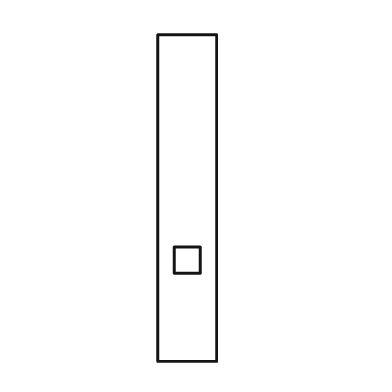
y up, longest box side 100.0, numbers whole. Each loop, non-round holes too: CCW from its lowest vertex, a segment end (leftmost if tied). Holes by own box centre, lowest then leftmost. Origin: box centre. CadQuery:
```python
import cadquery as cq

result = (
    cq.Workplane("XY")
    .moveTo(-9.0, -50.0)
    .lineTo(9.0, -50.0)
    .lineTo(9.0, 50.0)
    .lineTo(-9.0, 50.0)
    .close()
    .moveTo(-4.0, -23.0)
    .lineTo(4.0, -23.0)
    .lineTo(4.0, -15.0)
    .lineTo(-4.0, -15.0)
    .close()
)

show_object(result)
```